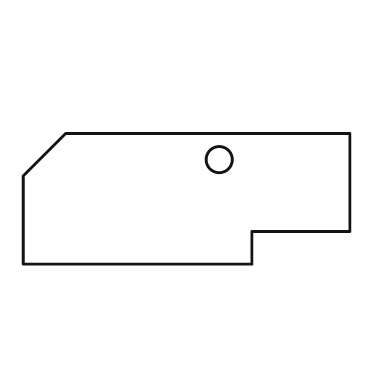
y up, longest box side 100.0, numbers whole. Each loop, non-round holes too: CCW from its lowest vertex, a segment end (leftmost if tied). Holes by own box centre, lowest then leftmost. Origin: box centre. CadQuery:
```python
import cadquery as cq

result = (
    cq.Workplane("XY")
    .moveTo(-50.0, -20.0)
    .lineTo(20.0, -20.0)
    .lineTo(20.0, -10.0)
    .lineTo(50.0, -10.0)
    .lineTo(50.0, 20.0)
    .lineTo(-37.0, 20.0)
    .lineTo(-50.0, 7.0)
    .close()
    .moveTo(10.0, 12.0)
    .circle(4.0)
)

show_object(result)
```